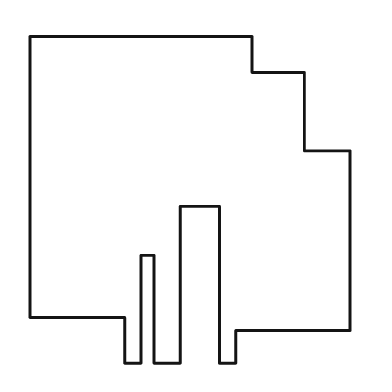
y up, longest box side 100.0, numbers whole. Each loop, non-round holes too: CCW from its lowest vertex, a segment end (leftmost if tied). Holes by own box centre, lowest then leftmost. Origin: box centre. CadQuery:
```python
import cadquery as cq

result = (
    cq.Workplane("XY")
    .moveTo(-20.0, -50.0)
    .lineTo(-15.0, -50.0)
    .lineTo(-15.0, -17.0)
    .lineTo(-11.0, -17.0)
    .lineTo(-11.0, -50.0)
    .lineTo(-3.0, -50.0)
    .lineTo(-3.0, -2.0)
    .lineTo(9.0, -2.0)
    .lineTo(9.0, -50.0)
    .lineTo(14.0, -50.0)
    .lineTo(14.0, -40.0)
    .lineTo(49.0, -40.0)
    .lineTo(49.0, 15.0)
    .lineTo(35.0, 15.0)
    .lineTo(35.0, 39.0)
    .lineTo(19.0, 39.0)
    .lineTo(19.0, 50.0)
    .lineTo(-49.0, 50.0)
    .lineTo(-49.0, -36.0)
    .lineTo(-20.0, -36.0)
    .close()
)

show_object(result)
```